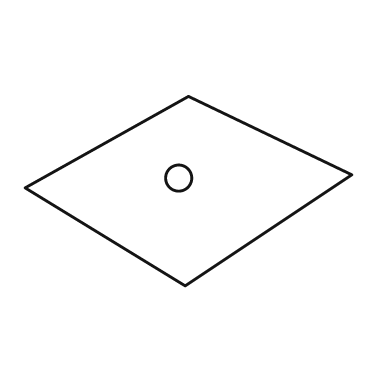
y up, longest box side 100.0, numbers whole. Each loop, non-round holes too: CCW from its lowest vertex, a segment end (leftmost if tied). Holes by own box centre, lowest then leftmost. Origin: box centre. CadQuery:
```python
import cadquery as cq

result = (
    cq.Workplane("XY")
    .moveTo(-1.0, -29.0)
    .lineTo(50.0, 5.0)
    .lineTo(0.0, 29.0)
    .lineTo(-50.0, 1.0)
    .close()
    .moveTo(-3.0, 4.0)
    .circle(4.0)
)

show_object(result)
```